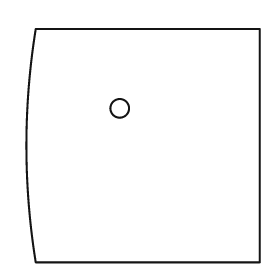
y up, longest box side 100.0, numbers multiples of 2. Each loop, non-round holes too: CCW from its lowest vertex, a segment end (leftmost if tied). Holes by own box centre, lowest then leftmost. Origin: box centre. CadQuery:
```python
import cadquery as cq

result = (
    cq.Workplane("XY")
    .moveTo(-46.0, -50.0)
    .lineTo(50.0, -50.0)
    .lineTo(50.0, 50.0)
    .lineTo(-46.0, 50.0)
    .threePointArc((-50.0, 0.0), (-46.0, -50.0))
    .close()
    .moveTo(-10.0, 16.0)
    .circle(4.0)
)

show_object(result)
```